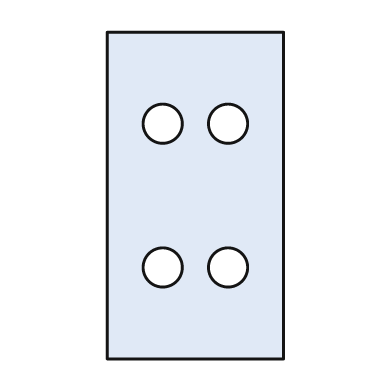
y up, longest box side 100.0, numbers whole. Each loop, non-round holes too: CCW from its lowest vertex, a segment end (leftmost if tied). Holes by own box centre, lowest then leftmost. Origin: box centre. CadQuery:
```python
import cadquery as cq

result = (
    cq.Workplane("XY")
    .moveTo(-27.0, -50.0)
    .lineTo(27.0, -50.0)
    .lineTo(27.0, 50.0)
    .lineTo(-27.0, 50.0)
    .close()
    .moveTo(-10.0, -22.0)
    .circle(6.0)
    .moveTo(10.0, -22.0)
    .circle(6.0)
    .moveTo(-10.0, 22.0)
    .circle(6.0)
    .moveTo(10.0, 22.0)
    .circle(6.0)
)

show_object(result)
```